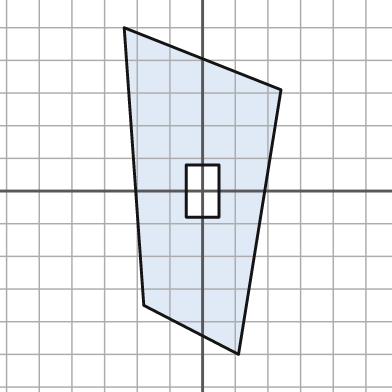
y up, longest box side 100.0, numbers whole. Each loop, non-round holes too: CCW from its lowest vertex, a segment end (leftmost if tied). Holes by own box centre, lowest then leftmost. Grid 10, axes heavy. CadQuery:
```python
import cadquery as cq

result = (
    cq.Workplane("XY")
    .moveTo(11.0, -50.0)
    .lineTo(24.0, 31.0)
    .lineTo(-24.0, 50.0)
    .lineTo(-18.0, -35.0)
    .close()
    .moveTo(-5.0, -8.0)
    .lineTo(5.0, -8.0)
    .lineTo(5.0, 8.0)
    .lineTo(-5.0, 8.0)
    .close()
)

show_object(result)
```